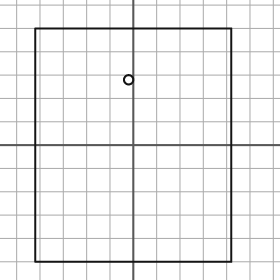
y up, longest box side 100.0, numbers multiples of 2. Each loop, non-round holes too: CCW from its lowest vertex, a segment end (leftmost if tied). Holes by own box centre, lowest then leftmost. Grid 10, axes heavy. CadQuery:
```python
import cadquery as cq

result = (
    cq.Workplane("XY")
    .moveTo(-42.0, -50.0)
    .lineTo(42.0, -50.0)
    .lineTo(42.0, 50.0)
    .lineTo(-42.0, 50.0)
    .close()
    .moveTo(-2.0, 28.0)
    .circle(2.0)
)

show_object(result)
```